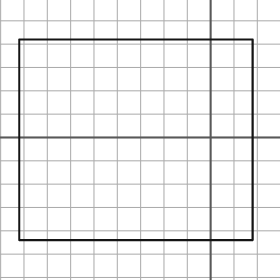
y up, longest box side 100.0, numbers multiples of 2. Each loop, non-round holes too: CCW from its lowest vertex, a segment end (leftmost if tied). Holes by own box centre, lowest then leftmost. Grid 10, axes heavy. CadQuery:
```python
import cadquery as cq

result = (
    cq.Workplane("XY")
    .moveTo(-82.0, -44.0)
    .lineTo(18.0, -44.0)
    .lineTo(18.0, 42.0)
    .lineTo(-82.0, 42.0)
    .close()
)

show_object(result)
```